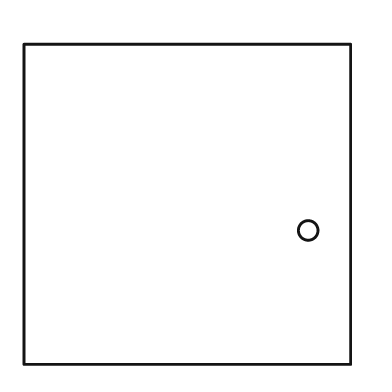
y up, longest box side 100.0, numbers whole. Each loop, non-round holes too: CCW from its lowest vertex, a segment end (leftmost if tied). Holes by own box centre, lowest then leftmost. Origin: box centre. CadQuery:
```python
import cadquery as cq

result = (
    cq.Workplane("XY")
    .moveTo(-50.0, -49.0)
    .lineTo(50.0, -49.0)
    .lineTo(50.0, 49.0)
    .lineTo(-50.0, 49.0)
    .close()
    .moveTo(37.0, -8.0)
    .circle(3.0)
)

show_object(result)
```